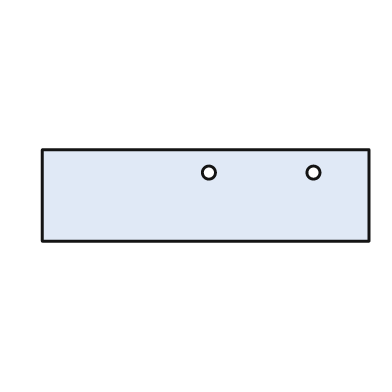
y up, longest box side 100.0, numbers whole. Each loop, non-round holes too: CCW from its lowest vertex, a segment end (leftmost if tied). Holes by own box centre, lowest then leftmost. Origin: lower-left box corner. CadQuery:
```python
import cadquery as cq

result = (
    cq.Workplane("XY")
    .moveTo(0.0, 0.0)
    .lineTo(100.0, 0.0)
    .lineTo(100.0, 28.0)
    .lineTo(0.0, 28.0)
    .close()
    .moveTo(51.0, 21.0)
    .circle(2.0)
    .moveTo(83.0, 21.0)
    .circle(2.0)
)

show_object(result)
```